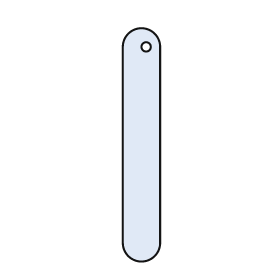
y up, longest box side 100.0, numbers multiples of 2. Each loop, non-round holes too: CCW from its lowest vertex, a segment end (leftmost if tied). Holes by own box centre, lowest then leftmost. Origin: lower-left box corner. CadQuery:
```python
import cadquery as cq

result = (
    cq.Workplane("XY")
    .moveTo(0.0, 8.0)
    .threePointArc((8.0, 0.0), (16.0, 8.0))
    .lineTo(16.0, 92.0)
    .threePointArc((8.0, 100.0), (0.0, 92.0))
    .close()
    .moveTo(10.0, 92.0)
    .circle(2.0)
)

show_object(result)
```